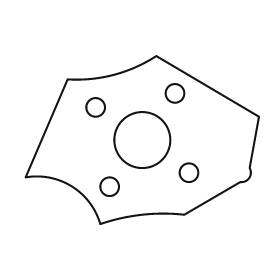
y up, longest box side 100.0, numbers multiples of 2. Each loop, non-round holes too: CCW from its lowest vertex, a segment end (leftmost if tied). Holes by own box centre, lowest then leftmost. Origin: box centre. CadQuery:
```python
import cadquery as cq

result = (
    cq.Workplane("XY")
    .moveTo(-18.0, -36.0)
    .threePointArc((0.0, -32.0), (18.0, -32.0))
    .lineTo(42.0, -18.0)
    .threePointArc((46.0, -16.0), (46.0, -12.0))
    .lineTo(50.0, 10.0)
    .lineTo(6.0, 36.0)
    .threePointArc((-12.0, 28.0), (-32.0, 26.0))
    .lineTo(-50.0, -16.0)
    .threePointArc((-30.0, -20.0), (-18.0, -36.0))
    .close()
    .moveTo(-14.0, -20.0)
    .circle(4.0)
    .moveTo(20.0, -14.0)
    .circle(4.0)
    .moveTo(0.0, 0.0)
    .circle(12.0)
    .moveTo(-20.0, 14.0)
    .circle(4.0)
    .moveTo(14.0, 20.0)
    .circle(4.0)
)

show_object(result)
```